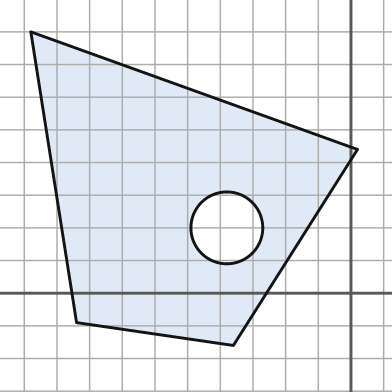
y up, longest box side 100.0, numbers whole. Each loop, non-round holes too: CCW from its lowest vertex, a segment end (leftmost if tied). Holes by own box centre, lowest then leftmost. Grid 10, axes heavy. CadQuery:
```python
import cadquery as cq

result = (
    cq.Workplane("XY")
    .moveTo(-36.0, -16.0)
    .lineTo(2.0, 44.0)
    .lineTo(-98.0, 80.0)
    .lineTo(-84.0, -9.0)
    .close()
    .moveTo(-38.0, 20.0)
    .circle(11.0)
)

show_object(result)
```